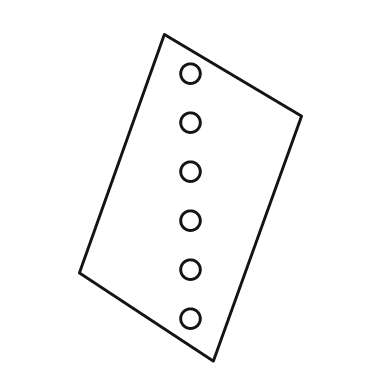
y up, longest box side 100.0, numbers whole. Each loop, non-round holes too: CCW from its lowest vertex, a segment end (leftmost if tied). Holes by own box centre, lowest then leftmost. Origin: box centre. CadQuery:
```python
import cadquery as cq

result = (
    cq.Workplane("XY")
    .moveTo(7.0, -50.0)
    .lineTo(34.0, 25.0)
    .lineTo(-8.0, 50.0)
    .lineTo(-34.0, -23.0)
    .close()
    .moveTo(0.0, -37.0)
    .circle(3.0)
    .moveTo(0.0, -22.0)
    .circle(3.0)
    .moveTo(0.0, -7.0)
    .circle(3.0)
    .moveTo(0.0, 8.0)
    .circle(3.0)
    .moveTo(0.0, 23.0)
    .circle(3.0)
    .moveTo(0.0, 38.0)
    .circle(3.0)
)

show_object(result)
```